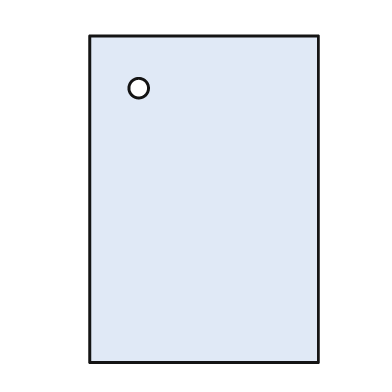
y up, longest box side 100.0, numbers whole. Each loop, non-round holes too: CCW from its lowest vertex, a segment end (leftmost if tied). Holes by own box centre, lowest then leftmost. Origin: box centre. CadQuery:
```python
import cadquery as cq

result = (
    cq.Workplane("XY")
    .moveTo(-35.0, -50.0)
    .lineTo(35.0, -50.0)
    .lineTo(35.0, 50.0)
    .lineTo(-35.0, 50.0)
    .close()
    .moveTo(-20.0, 34.0)
    .circle(3.0)
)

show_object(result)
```